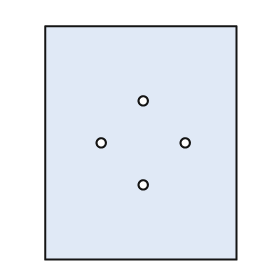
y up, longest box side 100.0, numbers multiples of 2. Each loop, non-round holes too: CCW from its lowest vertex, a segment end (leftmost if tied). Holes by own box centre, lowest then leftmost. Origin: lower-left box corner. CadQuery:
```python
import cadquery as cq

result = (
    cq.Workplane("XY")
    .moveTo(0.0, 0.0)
    .lineTo(82.0, 0.0)
    .lineTo(82.0, 100.0)
    .lineTo(0.0, 100.0)
    .close()
    .moveTo(42.0, 32.0)
    .circle(2.0)
    .moveTo(24.0, 50.0)
    .circle(2.0)
    .moveTo(60.0, 50.0)
    .circle(2.0)
    .moveTo(42.0, 68.0)
    .circle(2.0)
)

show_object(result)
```